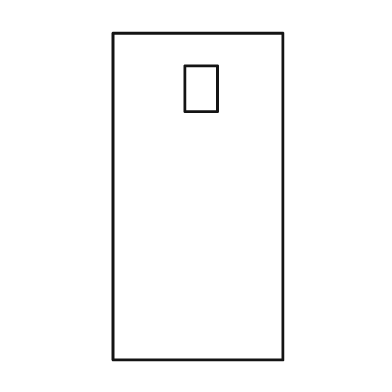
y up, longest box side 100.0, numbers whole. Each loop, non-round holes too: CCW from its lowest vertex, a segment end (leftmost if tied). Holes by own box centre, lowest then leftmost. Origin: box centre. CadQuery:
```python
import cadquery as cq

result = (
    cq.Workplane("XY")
    .moveTo(-26.0, -50.0)
    .lineTo(26.0, -50.0)
    .lineTo(26.0, 50.0)
    .lineTo(-26.0, 50.0)
    .close()
    .moveTo(-4.0, 26.0)
    .lineTo(6.0, 26.0)
    .lineTo(6.0, 40.0)
    .lineTo(-4.0, 40.0)
    .close()
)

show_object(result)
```